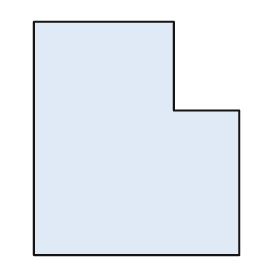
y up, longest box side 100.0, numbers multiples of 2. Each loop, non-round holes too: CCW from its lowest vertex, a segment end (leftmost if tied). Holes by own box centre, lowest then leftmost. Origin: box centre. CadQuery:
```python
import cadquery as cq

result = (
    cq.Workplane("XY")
    .moveTo(-44.0, -50.0)
    .lineTo(44.0, -50.0)
    .lineTo(44.0, 12.0)
    .lineTo(16.0, 12.0)
    .lineTo(16.0, 50.0)
    .lineTo(-44.0, 50.0)
    .close()
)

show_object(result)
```